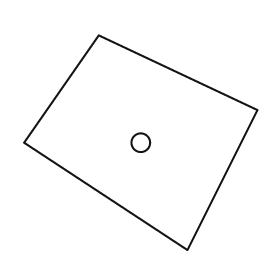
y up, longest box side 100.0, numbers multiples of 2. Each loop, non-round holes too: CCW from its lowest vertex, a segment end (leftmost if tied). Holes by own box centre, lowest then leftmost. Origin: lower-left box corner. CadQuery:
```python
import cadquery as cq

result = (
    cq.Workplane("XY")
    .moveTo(70.0, 0.0)
    .lineTo(100.0, 60.0)
    .lineTo(32.0, 92.0)
    .lineTo(0.0, 46.0)
    .close()
    .moveTo(50.0, 46.0)
    .circle(4.0)
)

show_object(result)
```